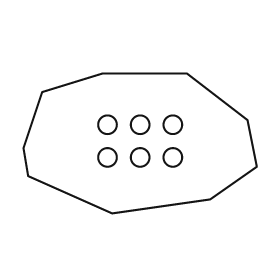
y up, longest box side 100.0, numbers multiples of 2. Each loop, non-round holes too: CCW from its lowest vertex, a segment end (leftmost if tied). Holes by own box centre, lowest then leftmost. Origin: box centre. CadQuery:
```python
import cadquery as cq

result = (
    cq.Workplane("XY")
    .moveTo(-12.0, -30.0)
    .lineTo(30.0, -24.0)
    .lineTo(50.0, -10.0)
    .lineTo(46.0, 10.0)
    .lineTo(20.0, 30.0)
    .lineTo(-16.0, 30.0)
    .lineTo(-42.0, 22.0)
    .lineTo(-50.0, -2.0)
    .lineTo(-48.0, -14.0)
    .close()
    .moveTo(-14.0, -6.0)
    .circle(4.0)
    .moveTo(0.0, -6.0)
    .circle(4.0)
    .moveTo(14.0, -6.0)
    .circle(4.0)
    .moveTo(-14.0, 8.0)
    .circle(4.0)
    .moveTo(0.0, 8.0)
    .circle(4.0)
    .moveTo(14.0, 8.0)
    .circle(4.0)
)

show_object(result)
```